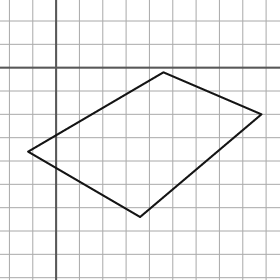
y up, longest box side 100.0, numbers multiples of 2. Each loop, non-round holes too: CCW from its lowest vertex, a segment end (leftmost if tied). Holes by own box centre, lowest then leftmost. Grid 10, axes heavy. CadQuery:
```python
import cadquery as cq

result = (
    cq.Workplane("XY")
    .moveTo(36.0, -64.0)
    .lineTo(88.0, -20.0)
    .lineTo(46.0, -2.0)
    .lineTo(-12.0, -36.0)
    .close()
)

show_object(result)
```